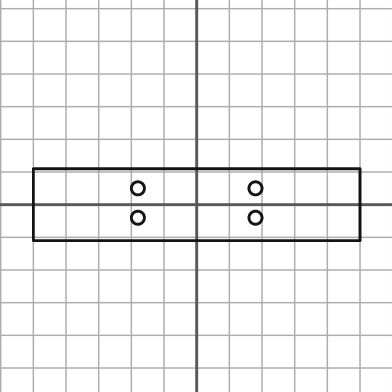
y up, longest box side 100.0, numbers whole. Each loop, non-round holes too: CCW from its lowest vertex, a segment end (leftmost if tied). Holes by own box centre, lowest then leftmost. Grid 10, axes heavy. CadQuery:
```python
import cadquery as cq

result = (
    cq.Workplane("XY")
    .moveTo(-50.0, -11.0)
    .lineTo(50.0, -11.0)
    .lineTo(50.0, 11.0)
    .lineTo(-50.0, 11.0)
    .close()
    .moveTo(-18.0, -4.0)
    .circle(2.0)
    .moveTo(18.0, -4.0)
    .circle(2.0)
    .moveTo(-18.0, 5.0)
    .circle(2.0)
    .moveTo(18.0, 5.0)
    .circle(2.0)
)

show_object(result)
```